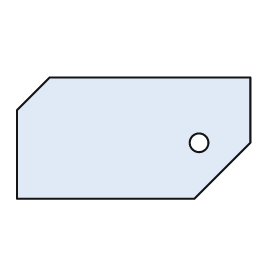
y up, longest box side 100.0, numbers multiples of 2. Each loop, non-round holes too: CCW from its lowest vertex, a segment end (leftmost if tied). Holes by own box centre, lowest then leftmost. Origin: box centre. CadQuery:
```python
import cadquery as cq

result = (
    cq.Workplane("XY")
    .moveTo(-50.0, -26.0)
    .lineTo(26.0, -26.0)
    .lineTo(50.0, -2.0)
    .lineTo(50.0, 26.0)
    .lineTo(-36.0, 26.0)
    .lineTo(-50.0, 12.0)
    .close()
    .moveTo(28.0, -2.0)
    .circle(4.0)
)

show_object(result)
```